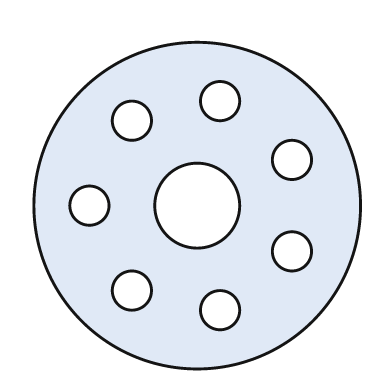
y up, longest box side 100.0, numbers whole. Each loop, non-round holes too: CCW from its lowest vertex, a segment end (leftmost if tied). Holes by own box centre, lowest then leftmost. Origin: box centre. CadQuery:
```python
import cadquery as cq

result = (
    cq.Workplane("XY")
    .moveTo(0.0, 0.0)
    .circle(50.0)
    .moveTo(7.0, -32.0)
    .circle(6.0)
    .moveTo(-20.0, -26.0)
    .circle(6.0)
    .moveTo(29.0, -14.0)
    .circle(6.0)
    .moveTo(-33.0, 0.0)
    .circle(6.0)
    .moveTo(0.0, 0.0)
    .circle(13.0)
    .moveTo(29.0, 14.0)
    .circle(6.0)
    .moveTo(-20.0, 26.0)
    .circle(6.0)
    .moveTo(7.0, 32.0)
    .circle(6.0)
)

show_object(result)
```